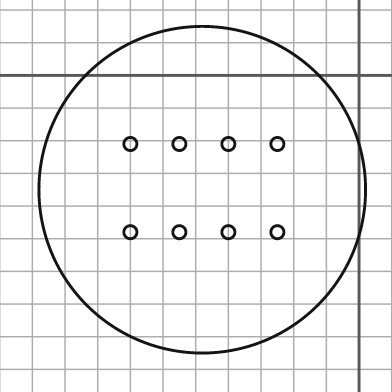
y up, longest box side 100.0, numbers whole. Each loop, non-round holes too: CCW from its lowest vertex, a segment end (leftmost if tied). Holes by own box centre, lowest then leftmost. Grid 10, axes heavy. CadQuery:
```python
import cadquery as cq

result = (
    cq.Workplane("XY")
    .moveTo(-48.0, -35.0)
    .circle(50.0)
    .moveTo(-70.0, -48.0)
    .circle(2.0)
    .moveTo(-55.0, -48.0)
    .circle(2.0)
    .moveTo(-40.0, -48.0)
    .circle(2.0)
    .moveTo(-25.0, -48.0)
    .circle(2.0)
    .moveTo(-70.0, -21.0)
    .circle(2.0)
    .moveTo(-55.0, -21.0)
    .circle(2.0)
    .moveTo(-40.0, -21.0)
    .circle(2.0)
    .moveTo(-25.0, -21.0)
    .circle(2.0)
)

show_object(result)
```